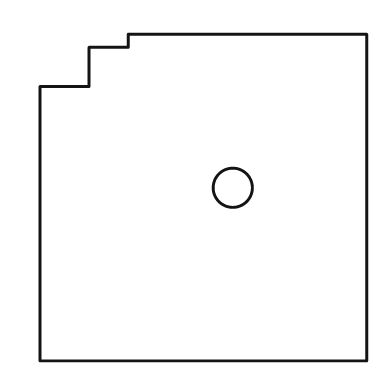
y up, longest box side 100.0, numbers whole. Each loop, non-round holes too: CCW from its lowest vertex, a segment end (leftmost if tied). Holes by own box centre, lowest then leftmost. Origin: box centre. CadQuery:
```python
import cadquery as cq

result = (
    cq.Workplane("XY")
    .moveTo(-50.0, -50.0)
    .lineTo(50.0, -50.0)
    .lineTo(50.0, 50.0)
    .lineTo(-23.0, 50.0)
    .lineTo(-23.0, 46.0)
    .lineTo(-35.0, 46.0)
    .lineTo(-35.0, 34.0)
    .lineTo(-50.0, 34.0)
    .close()
    .moveTo(9.0, 3.0)
    .circle(6.0)
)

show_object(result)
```